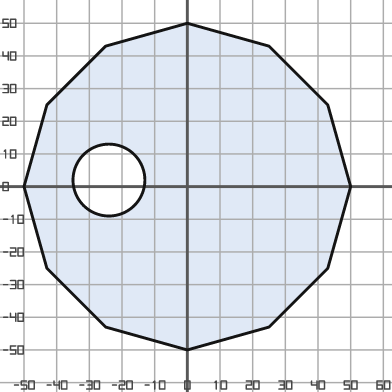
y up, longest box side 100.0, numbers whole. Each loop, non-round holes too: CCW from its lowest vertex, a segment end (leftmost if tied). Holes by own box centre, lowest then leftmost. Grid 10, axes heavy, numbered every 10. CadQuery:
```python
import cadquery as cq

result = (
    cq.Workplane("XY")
    .moveTo(0.0, -50.0)
    .lineTo(25.0, -43.0)
    .lineTo(43.0, -25.0)
    .lineTo(50.0, 0.0)
    .lineTo(43.0, 25.0)
    .lineTo(25.0, 43.0)
    .lineTo(0.0, 50.0)
    .lineTo(-25.0, 43.0)
    .lineTo(-43.0, 25.0)
    .lineTo(-50.0, 0.0)
    .lineTo(-43.0, -25.0)
    .lineTo(-25.0, -43.0)
    .close()
    .moveTo(-24.0, 2.0)
    .circle(11.0)
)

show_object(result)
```